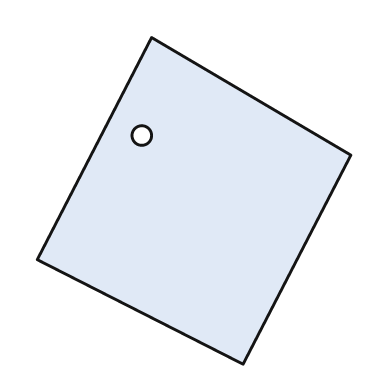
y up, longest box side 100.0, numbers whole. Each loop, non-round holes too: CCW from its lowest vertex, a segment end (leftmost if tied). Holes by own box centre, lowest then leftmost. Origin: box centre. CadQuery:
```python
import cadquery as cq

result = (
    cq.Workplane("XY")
    .moveTo(15.0, -50.0)
    .lineTo(48.0, 14.0)
    .lineTo(-13.0, 50.0)
    .lineTo(-48.0, -18.0)
    .close()
    .moveTo(-16.0, 20.0)
    .circle(3.0)
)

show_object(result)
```